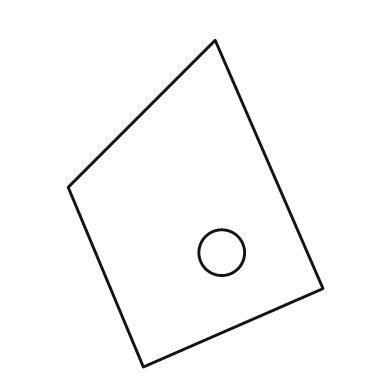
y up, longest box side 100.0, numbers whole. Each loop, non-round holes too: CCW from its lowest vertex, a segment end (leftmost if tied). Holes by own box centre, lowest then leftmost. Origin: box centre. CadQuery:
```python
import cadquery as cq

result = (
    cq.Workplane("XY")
    .moveTo(-16.0, -50.0)
    .lineTo(39.0, -26.0)
    .lineTo(6.0, 50.0)
    .lineTo(-39.0, 5.0)
    .close()
    .moveTo(8.0, -15.0)
    .circle(7.0)
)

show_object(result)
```